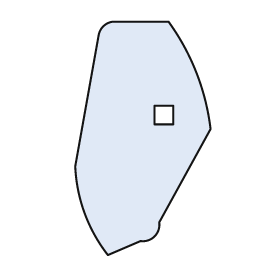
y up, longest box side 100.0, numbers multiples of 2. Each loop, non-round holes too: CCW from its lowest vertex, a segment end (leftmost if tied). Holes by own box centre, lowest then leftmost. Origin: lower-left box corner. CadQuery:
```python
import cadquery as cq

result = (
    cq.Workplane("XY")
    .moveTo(14.0, 0.0)
    .lineTo(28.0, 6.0)
    .threePointArc((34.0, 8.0), (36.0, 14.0))
    .lineTo(58.0, 54.0)
    .threePointArc((52.0, 78.0), (40.0, 100.0))
    .lineTo(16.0, 100.0)
    .threePointArc((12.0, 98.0), (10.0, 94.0))
    .lineTo(0.0, 38.0)
    .threePointArc((4.0, 18.0), (14.0, 0.0))
    .close()
    .moveTo(34.0, 56.0)
    .lineTo(42.0, 56.0)
    .lineTo(42.0, 64.0)
    .lineTo(34.0, 64.0)
    .close()
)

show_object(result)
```